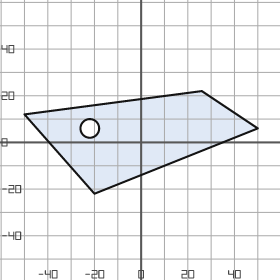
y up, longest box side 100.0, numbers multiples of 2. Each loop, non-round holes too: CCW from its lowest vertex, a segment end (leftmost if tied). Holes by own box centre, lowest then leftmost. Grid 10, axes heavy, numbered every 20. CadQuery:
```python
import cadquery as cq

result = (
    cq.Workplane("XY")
    .moveTo(-20.0, -22.0)
    .lineTo(50.0, 6.0)
    .lineTo(26.0, 22.0)
    .lineTo(-50.0, 12.0)
    .close()
    .moveTo(-22.0, 6.0)
    .circle(4.0)
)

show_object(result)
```